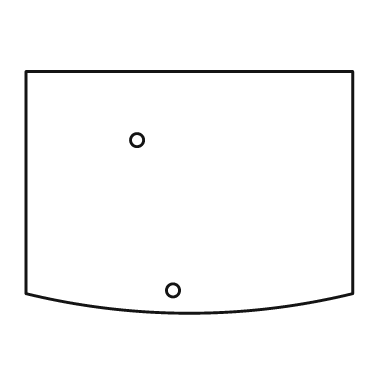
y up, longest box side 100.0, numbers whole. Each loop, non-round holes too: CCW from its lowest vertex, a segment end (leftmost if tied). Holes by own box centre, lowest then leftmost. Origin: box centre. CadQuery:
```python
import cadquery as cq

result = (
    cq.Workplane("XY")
    .moveTo(-50.0, -31.0)
    .threePointArc((0.0, -37.0), (50.0, -31.0))
    .lineTo(50.0, 37.0)
    .lineTo(-50.0, 37.0)
    .close()
    .moveTo(-5.0, -30.0)
    .circle(2.0)
    .moveTo(-16.0, 16.0)
    .circle(2.0)
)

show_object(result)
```